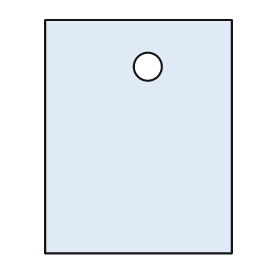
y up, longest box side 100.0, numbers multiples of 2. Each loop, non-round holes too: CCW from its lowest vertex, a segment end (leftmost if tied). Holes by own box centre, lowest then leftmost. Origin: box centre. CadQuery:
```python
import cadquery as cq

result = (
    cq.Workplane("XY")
    .moveTo(-40.0, -50.0)
    .lineTo(40.0, -50.0)
    .lineTo(40.0, 50.0)
    .lineTo(-40.0, 50.0)
    .close()
    .moveTo(4.0, 30.0)
    .circle(6.0)
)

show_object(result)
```